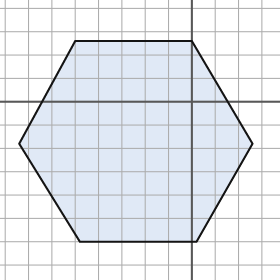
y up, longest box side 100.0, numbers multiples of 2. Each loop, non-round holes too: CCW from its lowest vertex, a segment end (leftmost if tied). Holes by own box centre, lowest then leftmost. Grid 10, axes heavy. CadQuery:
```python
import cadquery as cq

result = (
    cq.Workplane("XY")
    .moveTo(-48.0, -60.0)
    .lineTo(2.0, -60.0)
    .lineTo(26.0, -18.0)
    .lineTo(0.0, 26.0)
    .lineTo(-50.0, 26.0)
    .lineTo(-74.0, -18.0)
    .close()
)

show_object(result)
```